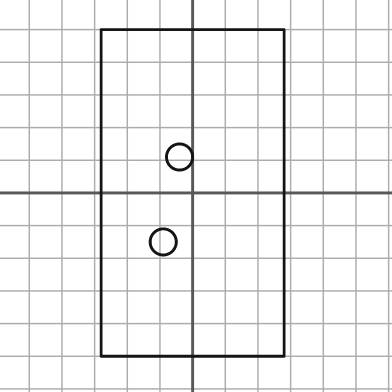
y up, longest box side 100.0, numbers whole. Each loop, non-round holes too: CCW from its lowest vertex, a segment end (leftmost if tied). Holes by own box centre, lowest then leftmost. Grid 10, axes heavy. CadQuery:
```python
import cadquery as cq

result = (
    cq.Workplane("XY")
    .moveTo(-28.0, -50.0)
    .lineTo(28.0, -50.0)
    .lineTo(28.0, 50.0)
    .lineTo(-28.0, 50.0)
    .close()
    .moveTo(-9.0, -15.0)
    .circle(4.0)
    .moveTo(-4.0, 11.0)
    .circle(4.0)
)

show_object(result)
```